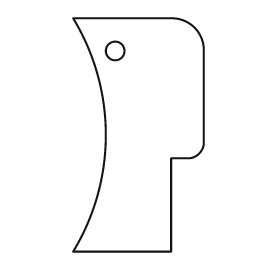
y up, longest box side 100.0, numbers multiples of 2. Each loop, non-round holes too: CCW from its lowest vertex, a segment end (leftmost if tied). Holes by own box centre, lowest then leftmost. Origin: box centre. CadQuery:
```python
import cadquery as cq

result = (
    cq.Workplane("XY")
    .moveTo(-28.0, -50.0)
    .lineTo(14.0, -50.0)
    .lineTo(14.0, -10.0)
    .lineTo(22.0, -10.0)
    .threePointArc((26.0, -8.0), (28.0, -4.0))
    .lineTo(28.0, 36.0)
    .threePointArc((24.0, 46.0), (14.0, 50.0))
    .lineTo(-28.0, 50.0)
    .threePointArc((-14.0, 0.0), (-28.0, -50.0))
    .close()
    .moveTo(-10.0, 36.0)
    .circle(4.0)
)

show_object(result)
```